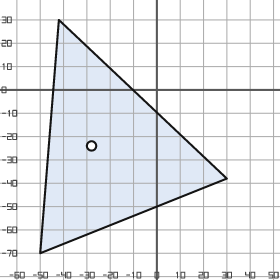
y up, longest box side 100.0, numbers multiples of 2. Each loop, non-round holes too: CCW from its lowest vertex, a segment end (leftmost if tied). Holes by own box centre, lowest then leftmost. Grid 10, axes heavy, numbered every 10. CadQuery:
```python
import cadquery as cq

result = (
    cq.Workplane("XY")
    .moveTo(-50.0, -70.0)
    .lineTo(30.0, -38.0)
    .lineTo(-42.0, 30.0)
    .close()
    .moveTo(-28.0, -24.0)
    .circle(2.0)
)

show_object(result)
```